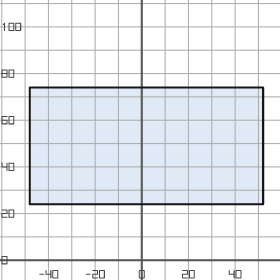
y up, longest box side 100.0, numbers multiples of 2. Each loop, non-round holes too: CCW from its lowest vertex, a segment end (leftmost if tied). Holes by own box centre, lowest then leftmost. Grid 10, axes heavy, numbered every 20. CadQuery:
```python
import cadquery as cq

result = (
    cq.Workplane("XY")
    .moveTo(-48.0, 24.0)
    .lineTo(52.0, 24.0)
    .lineTo(52.0, 74.0)
    .lineTo(-48.0, 74.0)
    .close()
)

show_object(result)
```